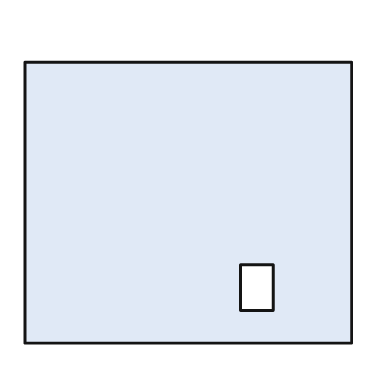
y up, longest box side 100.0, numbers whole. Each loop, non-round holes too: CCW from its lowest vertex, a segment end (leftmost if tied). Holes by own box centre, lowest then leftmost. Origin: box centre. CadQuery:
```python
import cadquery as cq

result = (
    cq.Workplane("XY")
    .moveTo(-50.0, -43.0)
    .lineTo(50.0, -43.0)
    .lineTo(50.0, 43.0)
    .lineTo(-50.0, 43.0)
    .close()
    .moveTo(16.0, -33.0)
    .lineTo(26.0, -33.0)
    .lineTo(26.0, -19.0)
    .lineTo(16.0, -19.0)
    .close()
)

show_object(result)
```